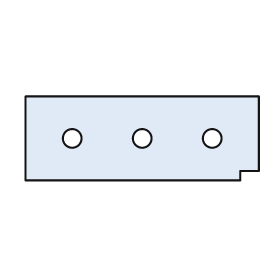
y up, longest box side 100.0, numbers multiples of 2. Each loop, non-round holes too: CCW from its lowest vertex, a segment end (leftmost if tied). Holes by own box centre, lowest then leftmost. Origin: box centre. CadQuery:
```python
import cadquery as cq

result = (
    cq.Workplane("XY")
    .moveTo(-50.0, -18.0)
    .lineTo(42.0, -18.0)
    .lineTo(42.0, -14.0)
    .lineTo(50.0, -14.0)
    .lineTo(50.0, 18.0)
    .lineTo(-50.0, 18.0)
    .close()
    .moveTo(-30.0, 0.0)
    .circle(4.0)
    .moveTo(0.0, 0.0)
    .circle(4.0)
    .moveTo(30.0, 0.0)
    .circle(4.0)
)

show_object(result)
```